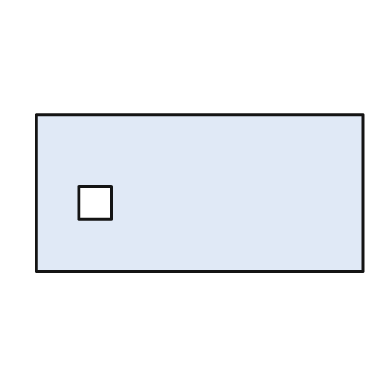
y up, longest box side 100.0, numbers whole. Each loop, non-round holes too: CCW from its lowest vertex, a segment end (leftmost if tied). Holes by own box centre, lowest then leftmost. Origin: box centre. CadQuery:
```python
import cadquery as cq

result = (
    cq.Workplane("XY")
    .moveTo(-50.0, -24.0)
    .lineTo(50.0, -24.0)
    .lineTo(50.0, 24.0)
    .lineTo(-50.0, 24.0)
    .close()
    .moveTo(-37.0, -8.0)
    .lineTo(-27.0, -8.0)
    .lineTo(-27.0, 2.0)
    .lineTo(-37.0, 2.0)
    .close()
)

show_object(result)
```